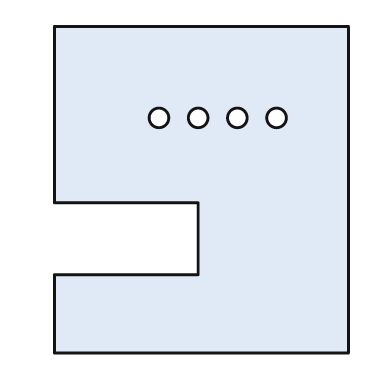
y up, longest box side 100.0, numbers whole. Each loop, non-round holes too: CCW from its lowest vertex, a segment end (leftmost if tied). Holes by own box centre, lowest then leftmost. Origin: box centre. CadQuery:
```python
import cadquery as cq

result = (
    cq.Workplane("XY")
    .moveTo(-45.0, -50.0)
    .lineTo(45.0, -50.0)
    .lineTo(45.0, 50.0)
    .lineTo(-45.0, 50.0)
    .lineTo(-45.0, -4.0)
    .lineTo(-1.0, -4.0)
    .lineTo(-1.0, -26.0)
    .lineTo(-45.0, -26.0)
    .close()
    .moveTo(-13.0, 22.0)
    .circle(3.0)
    .moveTo(-1.0, 22.0)
    .circle(3.0)
    .moveTo(11.0, 22.0)
    .circle(3.0)
    .moveTo(23.0, 22.0)
    .circle(3.0)
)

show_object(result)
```